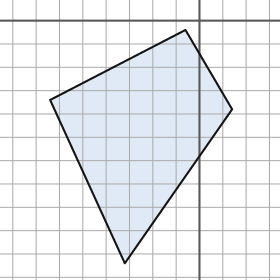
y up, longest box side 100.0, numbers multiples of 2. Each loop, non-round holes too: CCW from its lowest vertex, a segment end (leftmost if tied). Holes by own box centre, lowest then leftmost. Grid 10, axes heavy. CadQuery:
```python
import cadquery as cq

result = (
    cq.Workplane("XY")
    .moveTo(-32.0, -104.0)
    .lineTo(14.0, -38.0)
    .lineTo(-6.0, -4.0)
    .lineTo(-64.0, -34.0)
    .close()
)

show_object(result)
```